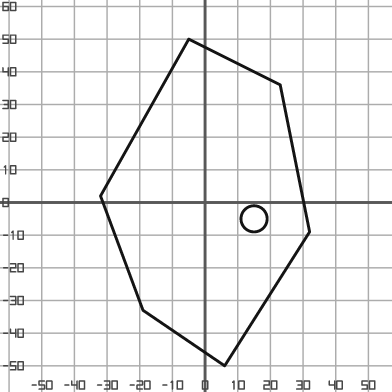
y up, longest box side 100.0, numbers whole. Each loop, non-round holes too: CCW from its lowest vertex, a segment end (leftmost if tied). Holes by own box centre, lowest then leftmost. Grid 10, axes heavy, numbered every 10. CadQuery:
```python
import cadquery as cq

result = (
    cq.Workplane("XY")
    .moveTo(6.0, -50.0)
    .lineTo(32.0, -9.0)
    .lineTo(23.0, 36.0)
    .lineTo(-5.0, 50.0)
    .lineTo(-32.0, 2.0)
    .lineTo(-19.0, -33.0)
    .close()
    .moveTo(15.0, -5.0)
    .circle(4.0)
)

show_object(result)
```